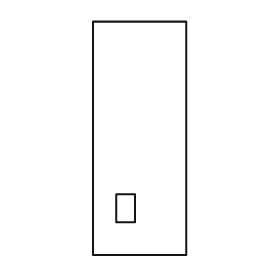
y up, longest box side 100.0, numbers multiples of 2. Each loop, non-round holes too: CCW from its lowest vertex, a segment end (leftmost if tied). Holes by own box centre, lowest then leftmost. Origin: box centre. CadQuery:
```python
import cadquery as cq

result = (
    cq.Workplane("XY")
    .moveTo(-20.0, -50.0)
    .lineTo(20.0, -50.0)
    .lineTo(20.0, 50.0)
    .lineTo(-20.0, 50.0)
    .close()
    .moveTo(-10.0, -36.0)
    .lineTo(-2.0, -36.0)
    .lineTo(-2.0, -24.0)
    .lineTo(-10.0, -24.0)
    .close()
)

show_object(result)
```